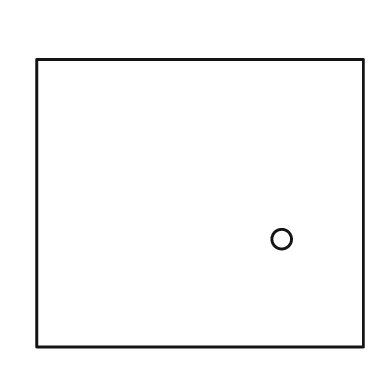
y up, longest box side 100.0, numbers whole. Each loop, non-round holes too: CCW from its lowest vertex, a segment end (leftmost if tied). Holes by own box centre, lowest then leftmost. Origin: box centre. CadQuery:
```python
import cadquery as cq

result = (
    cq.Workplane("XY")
    .moveTo(-50.0, -44.0)
    .lineTo(50.0, -44.0)
    .lineTo(50.0, 44.0)
    .lineTo(-50.0, 44.0)
    .close()
    .moveTo(25.0, -11.0)
    .circle(3.0)
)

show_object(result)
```